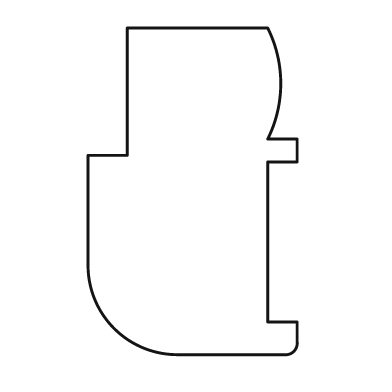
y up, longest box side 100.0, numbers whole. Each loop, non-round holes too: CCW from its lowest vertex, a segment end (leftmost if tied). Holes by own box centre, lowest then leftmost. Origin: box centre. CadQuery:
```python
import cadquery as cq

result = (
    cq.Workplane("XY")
    .moveTo(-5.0, -50.0)
    .lineTo(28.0, -50.0)
    .threePointArc((31.0, -49.0), (32.0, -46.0))
    .lineTo(32.0, -40.0)
    .lineTo(23.0, -40.0)
    .lineTo(23.0, 9.0)
    .lineTo(32.0, 9.0)
    .lineTo(32.0, 16.0)
    .lineTo(23.0, 16.0)
    .threePointArc((27.0, 33.0), (23.0, 50.0))
    .lineTo(-20.0, 50.0)
    .lineTo(-20.0, 11.0)
    .lineTo(-32.0, 11.0)
    .lineTo(-32.0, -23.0)
    .threePointArc((-24.0, -42.0), (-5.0, -50.0))
    .close()
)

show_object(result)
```